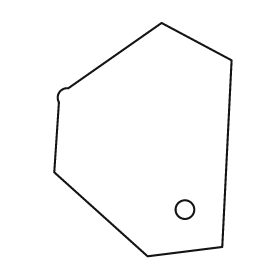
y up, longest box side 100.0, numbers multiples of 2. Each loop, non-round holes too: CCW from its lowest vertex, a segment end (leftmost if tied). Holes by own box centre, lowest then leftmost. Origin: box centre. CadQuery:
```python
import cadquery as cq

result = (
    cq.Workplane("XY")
    .moveTo(2.0, -50.0)
    .lineTo(34.0, -46.0)
    .lineTo(38.0, 34.0)
    .lineTo(8.0, 50.0)
    .lineTo(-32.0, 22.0)
    .threePointArc((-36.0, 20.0), (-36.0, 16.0))
    .lineTo(-38.0, -14.0)
    .close()
    .moveTo(18.0, -30.0)
    .circle(4.0)
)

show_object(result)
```